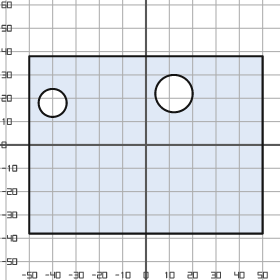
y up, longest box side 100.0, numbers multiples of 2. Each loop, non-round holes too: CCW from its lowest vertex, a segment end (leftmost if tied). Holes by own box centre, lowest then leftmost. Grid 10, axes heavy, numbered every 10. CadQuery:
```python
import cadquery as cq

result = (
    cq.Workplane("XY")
    .moveTo(-50.0, -38.0)
    .lineTo(50.0, -38.0)
    .lineTo(50.0, 38.0)
    .lineTo(-50.0, 38.0)
    .close()
    .moveTo(-40.0, 18.0)
    .circle(6.0)
    .moveTo(12.0, 22.0)
    .circle(8.0)
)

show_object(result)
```